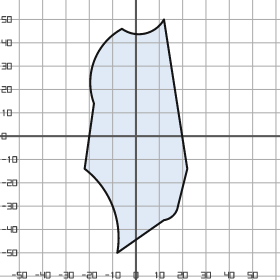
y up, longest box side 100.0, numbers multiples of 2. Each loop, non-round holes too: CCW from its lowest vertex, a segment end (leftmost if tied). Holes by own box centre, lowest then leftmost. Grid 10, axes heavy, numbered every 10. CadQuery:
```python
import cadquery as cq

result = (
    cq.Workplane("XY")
    .moveTo(-8.0, -50.0)
    .lineTo(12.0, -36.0)
    .threePointArc((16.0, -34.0), (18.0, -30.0))
    .lineTo(22.0, -14.0)
    .lineTo(12.0, 50.0)
    .threePointArc((4.0, 44.0), (-6.0, 46.0))
    .threePointArc((-18.0, 32.0), (-18.0, 14.0))
    .lineTo(-22.0, -14.0)
    .threePointArc((-10.0, -30.0), (-8.0, -50.0))
    .close()
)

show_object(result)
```